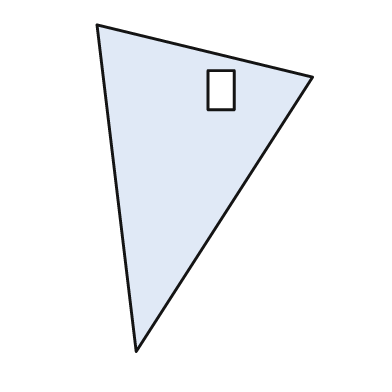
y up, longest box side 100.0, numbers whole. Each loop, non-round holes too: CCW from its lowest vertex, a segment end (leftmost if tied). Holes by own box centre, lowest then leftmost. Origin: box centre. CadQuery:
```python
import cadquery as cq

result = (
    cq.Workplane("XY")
    .moveTo(-21.0, -50.0)
    .lineTo(33.0, 34.0)
    .lineTo(-33.0, 50.0)
    .close()
    .moveTo(1.0, 24.0)
    .lineTo(9.0, 24.0)
    .lineTo(9.0, 36.0)
    .lineTo(1.0, 36.0)
    .close()
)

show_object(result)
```